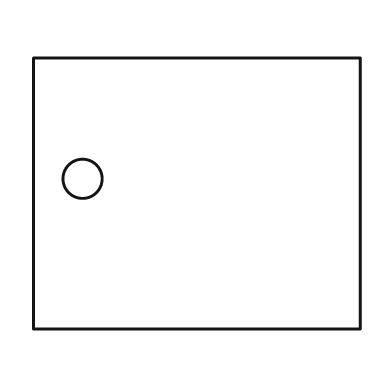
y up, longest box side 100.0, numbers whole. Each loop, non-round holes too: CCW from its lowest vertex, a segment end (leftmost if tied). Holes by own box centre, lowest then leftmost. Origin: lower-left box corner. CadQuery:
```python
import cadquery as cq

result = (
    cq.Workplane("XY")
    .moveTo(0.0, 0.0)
    .lineTo(100.0, 0.0)
    .lineTo(100.0, 83.0)
    .lineTo(0.0, 83.0)
    .close()
    .moveTo(15.0, 46.0)
    .circle(6.0)
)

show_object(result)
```